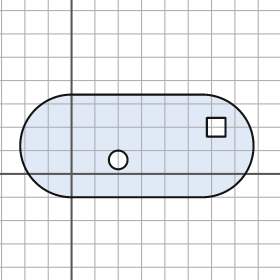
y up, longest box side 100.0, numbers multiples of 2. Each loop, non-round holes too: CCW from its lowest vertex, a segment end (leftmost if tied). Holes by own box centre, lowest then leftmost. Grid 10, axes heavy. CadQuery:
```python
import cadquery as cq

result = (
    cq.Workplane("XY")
    .moveTo(0.0, -10.0)
    .lineTo(56.0, -10.0)
    .threePointArc((78.0, 12.0), (56.0, 34.0))
    .lineTo(0.0, 34.0)
    .threePointArc((-22.0, 12.0), (0.0, -10.0))
    .close()
    .moveTo(20.0, 6.0)
    .circle(4.0)
    .moveTo(58.0, 16.0)
    .lineTo(66.0, 16.0)
    .lineTo(66.0, 24.0)
    .lineTo(58.0, 24.0)
    .close()
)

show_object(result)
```